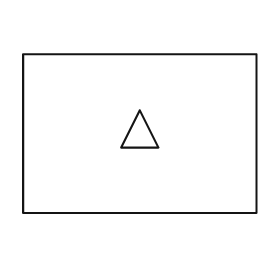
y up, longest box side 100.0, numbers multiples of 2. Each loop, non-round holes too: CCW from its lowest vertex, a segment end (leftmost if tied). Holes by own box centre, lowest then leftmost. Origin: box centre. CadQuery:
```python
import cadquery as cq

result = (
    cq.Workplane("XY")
    .moveTo(-50.0, -34.0)
    .lineTo(50.0, -34.0)
    .lineTo(50.0, 34.0)
    .lineTo(-50.0, 34.0)
    .close()
    .moveTo(-8.0, -6.0)
    .lineTo(8.0, -6.0)
    .lineTo(0.0, 10.0)
    .close()
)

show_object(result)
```